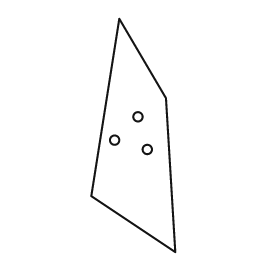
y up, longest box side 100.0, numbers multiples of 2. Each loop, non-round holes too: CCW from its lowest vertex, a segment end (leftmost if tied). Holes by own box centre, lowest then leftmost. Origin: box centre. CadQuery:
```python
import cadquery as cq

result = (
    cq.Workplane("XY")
    .moveTo(18.0, -50.0)
    .lineTo(14.0, 16.0)
    .lineTo(-6.0, 50.0)
    .lineTo(-18.0, -26.0)
    .close()
    .moveTo(6.0, -6.0)
    .circle(2.0)
    .moveTo(-8.0, -2.0)
    .circle(2.0)
    .moveTo(2.0, 8.0)
    .circle(2.0)
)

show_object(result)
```